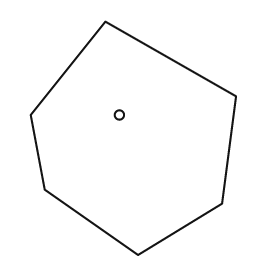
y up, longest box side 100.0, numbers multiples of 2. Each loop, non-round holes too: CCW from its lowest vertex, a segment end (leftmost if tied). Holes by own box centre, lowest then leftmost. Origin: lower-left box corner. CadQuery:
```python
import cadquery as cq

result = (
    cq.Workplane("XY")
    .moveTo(46.0, 0.0)
    .lineTo(82.0, 22.0)
    .lineTo(88.0, 68.0)
    .lineTo(32.0, 100.0)
    .lineTo(0.0, 60.0)
    .lineTo(6.0, 28.0)
    .close()
    .moveTo(38.0, 60.0)
    .circle(2.0)
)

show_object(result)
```